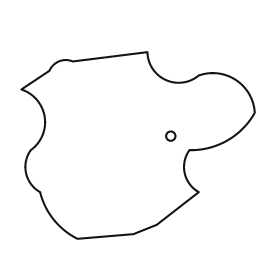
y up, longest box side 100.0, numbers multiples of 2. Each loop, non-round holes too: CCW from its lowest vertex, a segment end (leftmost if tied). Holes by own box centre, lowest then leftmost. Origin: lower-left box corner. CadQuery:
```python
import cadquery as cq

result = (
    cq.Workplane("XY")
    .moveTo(24.0, 0.0)
    .lineTo(48.0, 2.0)
    .lineTo(58.0, 6.0)
    .lineTo(76.0, 20.0)
    .threePointArc((70.0, 28.0), (72.0, 38.0))
    .threePointArc((88.0, 42.0), (100.0, 54.0))
    .threePointArc((92.0, 68.0), (76.0, 70.0))
    .threePointArc((62.0, 68.0), (54.0, 80.0))
    .lineTo(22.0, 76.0)
    .threePointArc((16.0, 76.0), (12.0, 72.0))
    .lineTo(0.0, 64.0)
    .threePointArc((10.0, 52.0), (4.0, 38.0))
    .threePointArc((2.0, 28.0), (8.0, 20.0))
    .threePointArc((14.0, 8.0), (24.0, 0.0))
    .close()
    .moveTo(64.0, 44.0)
    .circle(2.0)
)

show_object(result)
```